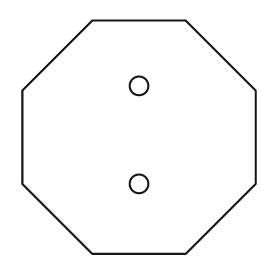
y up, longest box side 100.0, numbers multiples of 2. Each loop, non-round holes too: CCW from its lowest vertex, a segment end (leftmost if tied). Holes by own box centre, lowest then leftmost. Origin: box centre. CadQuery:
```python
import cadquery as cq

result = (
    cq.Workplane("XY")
    .moveTo(-20.0, -50.0)
    .lineTo(20.0, -50.0)
    .lineTo(50.0, -20.0)
    .lineTo(50.0, 20.0)
    .lineTo(20.0, 50.0)
    .lineTo(-20.0, 50.0)
    .lineTo(-50.0, 20.0)
    .lineTo(-50.0, -20.0)
    .close()
    .moveTo(0.0, -20.0)
    .circle(4.0)
    .moveTo(0.0, 22.0)
    .circle(4.0)
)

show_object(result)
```